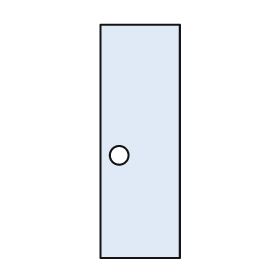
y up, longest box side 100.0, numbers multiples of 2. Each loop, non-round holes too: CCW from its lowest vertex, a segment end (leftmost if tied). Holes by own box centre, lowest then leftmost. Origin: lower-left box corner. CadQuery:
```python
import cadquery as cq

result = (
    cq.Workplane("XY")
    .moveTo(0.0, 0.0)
    .lineTo(34.0, 0.0)
    .lineTo(34.0, 100.0)
    .lineTo(0.0, 100.0)
    .close()
    .moveTo(8.0, 44.0)
    .circle(4.0)
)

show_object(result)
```